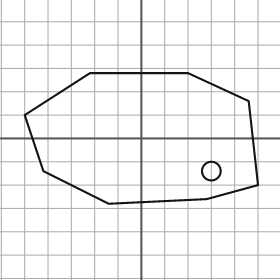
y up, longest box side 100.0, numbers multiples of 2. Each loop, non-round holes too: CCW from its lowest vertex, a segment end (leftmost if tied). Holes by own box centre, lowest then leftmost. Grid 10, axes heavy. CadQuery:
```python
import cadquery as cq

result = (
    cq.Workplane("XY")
    .moveTo(-14.0, -28.0)
    .lineTo(28.0, -26.0)
    .lineTo(50.0, -20.0)
    .lineTo(46.0, 16.0)
    .lineTo(20.0, 28.0)
    .lineTo(-22.0, 28.0)
    .lineTo(-50.0, 10.0)
    .lineTo(-42.0, -14.0)
    .close()
    .moveTo(30.0, -14.0)
    .circle(4.0)
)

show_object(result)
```